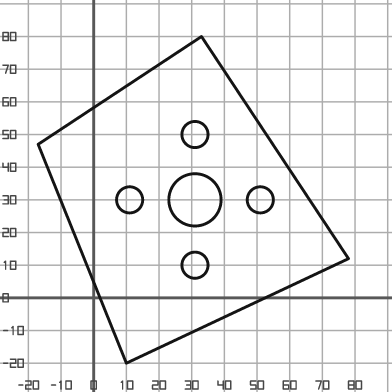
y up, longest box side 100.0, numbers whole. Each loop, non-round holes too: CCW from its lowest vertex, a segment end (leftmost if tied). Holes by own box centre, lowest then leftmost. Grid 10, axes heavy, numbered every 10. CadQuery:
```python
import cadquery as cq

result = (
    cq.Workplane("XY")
    .moveTo(10.0, -20.0)
    .lineTo(78.0, 12.0)
    .lineTo(33.0, 80.0)
    .lineTo(-17.0, 47.0)
    .close()
    .moveTo(31.0, 10.0)
    .circle(4.0)
    .moveTo(11.0, 30.0)
    .circle(4.0)
    .moveTo(31.0, 30.0)
    .circle(8.0)
    .moveTo(51.0, 30.0)
    .circle(4.0)
    .moveTo(31.0, 50.0)
    .circle(4.0)
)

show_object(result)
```